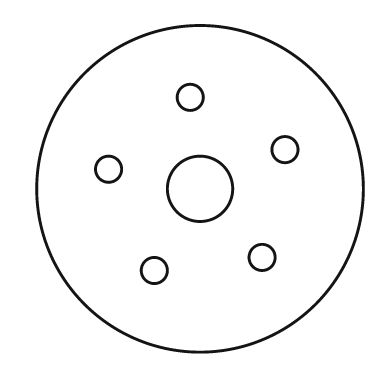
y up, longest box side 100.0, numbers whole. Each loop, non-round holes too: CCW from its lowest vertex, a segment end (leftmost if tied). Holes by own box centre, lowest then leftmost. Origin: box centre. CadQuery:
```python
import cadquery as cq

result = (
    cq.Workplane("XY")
    .moveTo(0.0, 0.0)
    .circle(50.0)
    .moveTo(-14.0, -25.0)
    .circle(4.0)
    .moveTo(19.0, -21.0)
    .circle(4.0)
    .moveTo(0.0, 0.0)
    .circle(10.0)
    .moveTo(-28.0, 6.0)
    .circle(4.0)
    .moveTo(26.0, 12.0)
    .circle(4.0)
    .moveTo(-3.0, 28.0)
    .circle(4.0)
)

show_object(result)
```